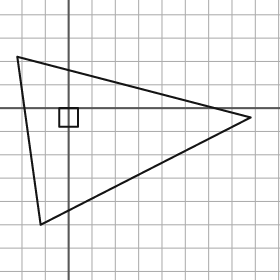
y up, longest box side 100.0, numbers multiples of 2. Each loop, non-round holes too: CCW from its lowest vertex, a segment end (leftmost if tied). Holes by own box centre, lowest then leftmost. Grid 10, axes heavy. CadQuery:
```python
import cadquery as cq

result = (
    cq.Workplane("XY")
    .moveTo(-12.0, -50.0)
    .lineTo(78.0, -4.0)
    .lineTo(-22.0, 22.0)
    .close()
    .moveTo(-4.0, -8.0)
    .lineTo(4.0, -8.0)
    .lineTo(4.0, 0.0)
    .lineTo(-4.0, 0.0)
    .close()
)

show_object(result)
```